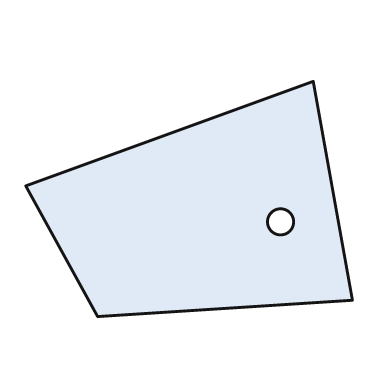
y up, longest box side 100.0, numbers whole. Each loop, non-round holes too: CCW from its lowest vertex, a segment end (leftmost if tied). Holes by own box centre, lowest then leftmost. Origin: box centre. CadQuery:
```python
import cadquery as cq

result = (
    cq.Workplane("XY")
    .moveTo(-28.0, -36.0)
    .lineTo(50.0, -31.0)
    .lineTo(38.0, 36.0)
    .lineTo(-50.0, 4.0)
    .close()
    .moveTo(28.0, -7.0)
    .circle(4.0)
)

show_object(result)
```